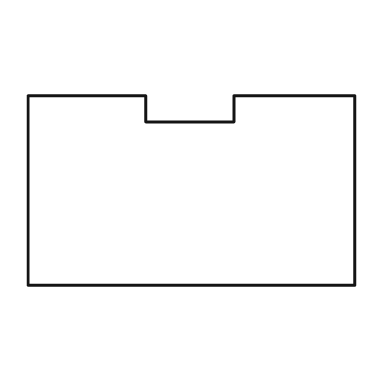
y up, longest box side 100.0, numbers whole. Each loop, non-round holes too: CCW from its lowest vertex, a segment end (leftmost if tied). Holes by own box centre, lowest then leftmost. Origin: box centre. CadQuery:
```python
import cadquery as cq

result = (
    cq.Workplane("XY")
    .moveTo(-50.0, -29.0)
    .lineTo(50.0, -29.0)
    .lineTo(50.0, 29.0)
    .lineTo(13.0, 29.0)
    .lineTo(13.0, 21.0)
    .lineTo(-14.0, 21.0)
    .lineTo(-14.0, 29.0)
    .lineTo(-50.0, 29.0)
    .close()
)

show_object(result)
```